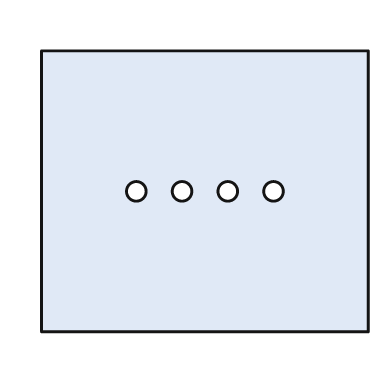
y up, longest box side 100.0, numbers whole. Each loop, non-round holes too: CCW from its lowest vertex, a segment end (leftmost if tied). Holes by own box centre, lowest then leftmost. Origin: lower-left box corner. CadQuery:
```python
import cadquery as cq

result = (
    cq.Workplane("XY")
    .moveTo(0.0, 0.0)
    .lineTo(100.0, 0.0)
    .lineTo(100.0, 86.0)
    .lineTo(0.0, 86.0)
    .close()
    .moveTo(29.0, 43.0)
    .circle(3.0)
    .moveTo(43.0, 43.0)
    .circle(3.0)
    .moveTo(57.0, 43.0)
    .circle(3.0)
    .moveTo(71.0, 43.0)
    .circle(3.0)
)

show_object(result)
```